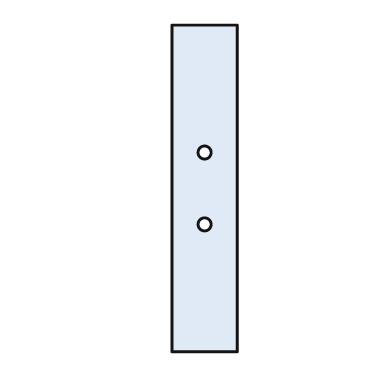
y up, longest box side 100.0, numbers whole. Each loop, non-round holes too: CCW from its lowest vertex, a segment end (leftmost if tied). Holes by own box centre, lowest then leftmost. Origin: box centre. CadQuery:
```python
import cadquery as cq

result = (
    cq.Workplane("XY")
    .moveTo(-10.0, -50.0)
    .lineTo(10.0, -50.0)
    .lineTo(10.0, 50.0)
    .lineTo(-10.0, 50.0)
    .close()
    .moveTo(0.0, -11.0)
    .circle(2.0)
    .moveTo(0.0, 11.0)
    .circle(2.0)
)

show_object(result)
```